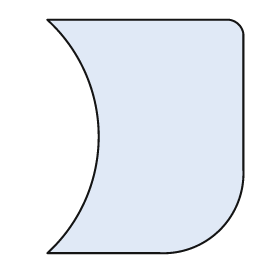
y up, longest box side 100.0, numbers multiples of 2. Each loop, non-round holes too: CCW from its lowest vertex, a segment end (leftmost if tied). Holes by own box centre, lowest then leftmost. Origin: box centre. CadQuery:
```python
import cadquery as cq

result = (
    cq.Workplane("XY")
    .moveTo(-42.0, -50.0)
    .lineTo(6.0, -50.0)
    .threePointArc((32.0, -40.0), (42.0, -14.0))
    .lineTo(42.0, 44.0)
    .threePointArc((40.0, 48.0), (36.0, 50.0))
    .lineTo(-42.0, 50.0)
    .threePointArc((-20.0, 0.0), (-42.0, -50.0))
    .close()
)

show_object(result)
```